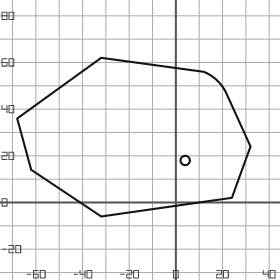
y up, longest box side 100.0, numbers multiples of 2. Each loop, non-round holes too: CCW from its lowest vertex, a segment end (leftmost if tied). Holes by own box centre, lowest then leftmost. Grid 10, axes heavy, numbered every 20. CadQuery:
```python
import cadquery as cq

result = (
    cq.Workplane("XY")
    .moveTo(-32.0, -6.0)
    .lineTo(24.0, 2.0)
    .lineTo(32.0, 24.0)
    .lineTo(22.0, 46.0)
    .threePointArc((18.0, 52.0), (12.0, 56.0))
    .lineTo(-32.0, 62.0)
    .lineTo(-68.0, 36.0)
    .lineTo(-62.0, 14.0)
    .close()
    .moveTo(4.0, 18.0)
    .circle(2.0)
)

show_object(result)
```